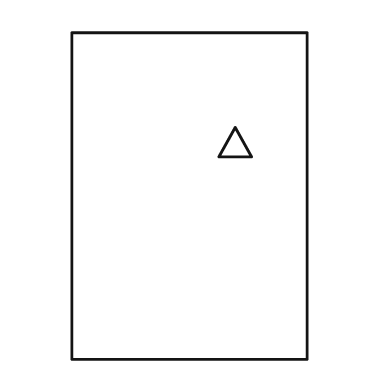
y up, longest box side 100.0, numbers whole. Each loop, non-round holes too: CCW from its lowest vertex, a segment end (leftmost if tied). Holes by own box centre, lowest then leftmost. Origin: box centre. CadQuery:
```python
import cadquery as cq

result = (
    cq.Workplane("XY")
    .moveTo(-36.0, -50.0)
    .lineTo(36.0, -50.0)
    .lineTo(36.0, 50.0)
    .lineTo(-36.0, 50.0)
    .close()
    .moveTo(9.0, 12.0)
    .lineTo(19.0, 12.0)
    .lineTo(14.0, 21.0)
    .close()
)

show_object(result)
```